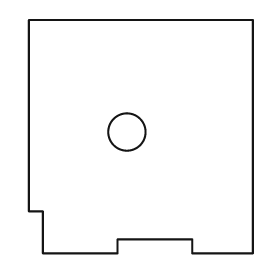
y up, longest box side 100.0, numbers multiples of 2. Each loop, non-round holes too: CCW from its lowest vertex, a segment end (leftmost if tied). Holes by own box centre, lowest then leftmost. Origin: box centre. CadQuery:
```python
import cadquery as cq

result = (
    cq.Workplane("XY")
    .moveTo(-42.0, -50.0)
    .lineTo(-10.0, -50.0)
    .lineTo(-10.0, -44.0)
    .lineTo(22.0, -44.0)
    .lineTo(22.0, -50.0)
    .lineTo(48.0, -50.0)
    .lineTo(48.0, 50.0)
    .lineTo(-48.0, 50.0)
    .lineTo(-48.0, -32.0)
    .lineTo(-42.0, -32.0)
    .close()
    .moveTo(-6.0, 2.0)
    .circle(8.0)
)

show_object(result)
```